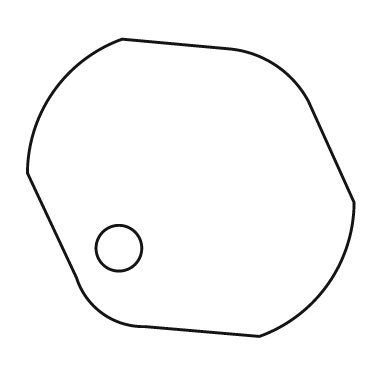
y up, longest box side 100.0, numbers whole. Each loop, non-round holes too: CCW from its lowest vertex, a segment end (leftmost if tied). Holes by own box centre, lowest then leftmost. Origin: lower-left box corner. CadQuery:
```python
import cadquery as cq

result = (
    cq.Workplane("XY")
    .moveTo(71.0, 0.0)
    .threePointArc((92.0, 16.0), (100.0, 41.0))
    .lineTo(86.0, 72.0)
    .threePointArc((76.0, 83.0), (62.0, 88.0))
    .lineTo(29.0, 91.0)
    .threePointArc((8.0, 75.0), (0.0, 50.0))
    .lineTo(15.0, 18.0)
    .threePointArc((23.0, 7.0), (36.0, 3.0))
    .close()
    .moveTo(28.0, 27.0)
    .circle(7.0)
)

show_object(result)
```